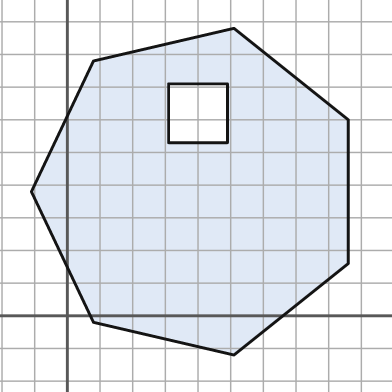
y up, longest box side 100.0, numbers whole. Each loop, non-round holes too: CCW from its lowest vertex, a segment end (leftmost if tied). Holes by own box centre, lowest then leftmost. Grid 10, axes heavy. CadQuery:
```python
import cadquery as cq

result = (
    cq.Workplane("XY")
    .moveTo(51.0, -12.0)
    .lineTo(86.0, 16.0)
    .lineTo(86.0, 60.0)
    .lineTo(51.0, 88.0)
    .lineTo(8.0, 78.0)
    .lineTo(-11.0, 38.0)
    .lineTo(8.0, -2.0)
    .close()
    .moveTo(31.0, 53.0)
    .lineTo(49.0, 53.0)
    .lineTo(49.0, 71.0)
    .lineTo(31.0, 71.0)
    .close()
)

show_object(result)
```